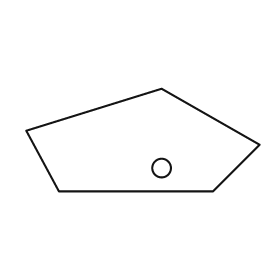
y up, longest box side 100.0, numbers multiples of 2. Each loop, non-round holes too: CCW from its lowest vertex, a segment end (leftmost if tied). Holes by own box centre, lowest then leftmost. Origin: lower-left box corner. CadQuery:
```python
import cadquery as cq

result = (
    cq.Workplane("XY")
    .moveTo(14.0, 0.0)
    .lineTo(80.0, 0.0)
    .lineTo(100.0, 20.0)
    .lineTo(58.0, 44.0)
    .lineTo(0.0, 26.0)
    .close()
    .moveTo(58.0, 10.0)
    .circle(4.0)
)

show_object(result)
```